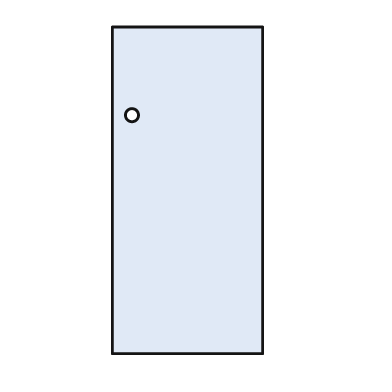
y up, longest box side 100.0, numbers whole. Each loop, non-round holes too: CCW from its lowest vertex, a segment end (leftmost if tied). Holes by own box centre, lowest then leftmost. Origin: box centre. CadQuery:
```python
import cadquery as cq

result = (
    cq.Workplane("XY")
    .moveTo(-23.0, -50.0)
    .lineTo(23.0, -50.0)
    .lineTo(23.0, 50.0)
    .lineTo(-23.0, 50.0)
    .close()
    .moveTo(-17.0, 23.0)
    .circle(2.0)
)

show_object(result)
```